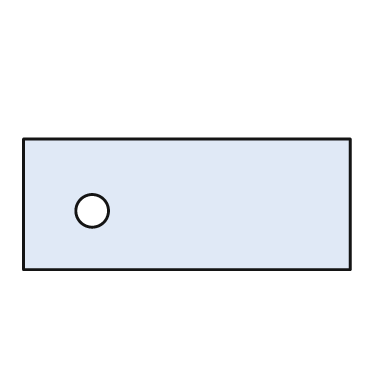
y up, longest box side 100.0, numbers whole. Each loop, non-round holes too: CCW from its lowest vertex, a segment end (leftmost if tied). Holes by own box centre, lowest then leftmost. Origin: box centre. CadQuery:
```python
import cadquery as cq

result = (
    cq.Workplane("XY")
    .moveTo(-50.0, -20.0)
    .lineTo(50.0, -20.0)
    .lineTo(50.0, 20.0)
    .lineTo(-50.0, 20.0)
    .close()
    .moveTo(-29.0, -2.0)
    .circle(5.0)
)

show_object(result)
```